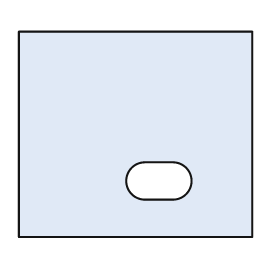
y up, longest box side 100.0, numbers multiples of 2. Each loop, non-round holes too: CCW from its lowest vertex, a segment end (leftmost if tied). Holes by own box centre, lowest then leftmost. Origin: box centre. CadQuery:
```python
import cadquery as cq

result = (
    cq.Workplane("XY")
    .moveTo(-50.0, -44.0)
    .lineTo(50.0, -44.0)
    .lineTo(50.0, 44.0)
    .lineTo(-50.0, 44.0)
    .close()
    .moveTo(4.0, -28.0)
    .lineTo(16.0, -28.0)
    .threePointArc((24.0, -20.0), (16.0, -12.0))
    .lineTo(4.0, -12.0)
    .threePointArc((-4.0, -20.0), (4.0, -28.0))
    .close()
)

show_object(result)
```